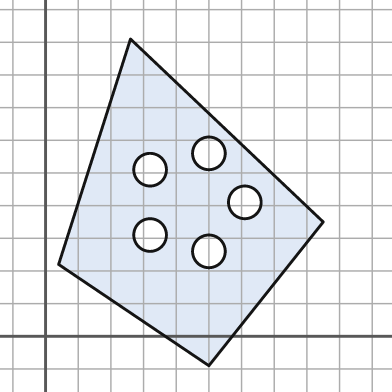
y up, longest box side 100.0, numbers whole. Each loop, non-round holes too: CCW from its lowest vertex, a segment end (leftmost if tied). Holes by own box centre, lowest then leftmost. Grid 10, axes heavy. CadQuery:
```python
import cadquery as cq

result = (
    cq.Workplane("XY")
    .moveTo(50.0, -9.0)
    .lineTo(85.0, 35.0)
    .lineTo(26.0, 91.0)
    .lineTo(4.0, 22.0)
    .close()
    .moveTo(50.0, 26.0)
    .circle(5.0)
    .moveTo(32.0, 31.0)
    .circle(5.0)
    .moveTo(61.0, 41.0)
    .circle(5.0)
    .moveTo(32.0, 51.0)
    .circle(5.0)
    .moveTo(50.0, 56.0)
    .circle(5.0)
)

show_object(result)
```